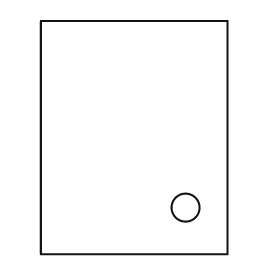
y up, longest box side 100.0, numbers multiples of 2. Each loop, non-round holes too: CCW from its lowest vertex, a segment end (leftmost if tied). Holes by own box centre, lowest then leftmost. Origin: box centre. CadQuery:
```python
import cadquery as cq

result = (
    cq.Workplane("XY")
    .moveTo(-40.0, -50.0)
    .lineTo(40.0, -50.0)
    .lineTo(40.0, 50.0)
    .lineTo(-40.0, 50.0)
    .close()
    .moveTo(22.0, -30.0)
    .circle(6.0)
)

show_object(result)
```